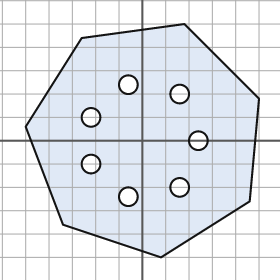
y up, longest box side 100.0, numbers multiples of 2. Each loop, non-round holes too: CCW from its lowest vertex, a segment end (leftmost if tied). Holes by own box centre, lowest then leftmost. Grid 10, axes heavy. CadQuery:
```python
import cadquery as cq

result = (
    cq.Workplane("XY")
    .moveTo(8.0, -50.0)
    .lineTo(46.0, -26.0)
    .lineTo(50.0, 18.0)
    .lineTo(18.0, 50.0)
    .lineTo(-26.0, 44.0)
    .lineTo(-50.0, 6.0)
    .lineTo(-34.0, -36.0)
    .close()
    .moveTo(-6.0, -24.0)
    .circle(4.0)
    .moveTo(16.0, -20.0)
    .circle(4.0)
    .moveTo(-22.0, -10.0)
    .circle(4.0)
    .moveTo(24.0, 0.0)
    .circle(4.0)
    .moveTo(-22.0, 10.0)
    .circle(4.0)
    .moveTo(16.0, 20.0)
    .circle(4.0)
    .moveTo(-6.0, 24.0)
    .circle(4.0)
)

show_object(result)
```